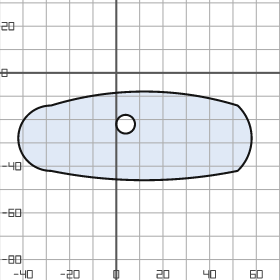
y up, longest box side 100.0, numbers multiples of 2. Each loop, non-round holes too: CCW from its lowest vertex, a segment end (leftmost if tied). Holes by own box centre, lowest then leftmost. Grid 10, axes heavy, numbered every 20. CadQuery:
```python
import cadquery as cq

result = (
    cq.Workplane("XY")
    .moveTo(-28.0, -42.0)
    .threePointArc((12.0, -46.0), (52.0, -42.0))
    .threePointArc((58.0, -28.0), (52.0, -14.0))
    .threePointArc((12.0, -8.0), (-28.0, -14.0))
    .threePointArc((-42.0, -28.0), (-28.0, -42.0))
    .close()
    .moveTo(4.0, -22.0)
    .circle(4.0)
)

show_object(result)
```